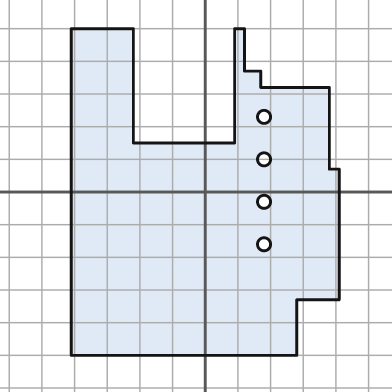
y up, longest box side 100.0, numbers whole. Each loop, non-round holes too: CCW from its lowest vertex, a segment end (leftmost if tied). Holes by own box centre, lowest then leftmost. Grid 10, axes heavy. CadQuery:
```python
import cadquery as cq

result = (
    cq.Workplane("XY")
    .moveTo(-41.0, -50.0)
    .lineTo(28.0, -50.0)
    .lineTo(28.0, -33.0)
    .lineTo(41.0, -33.0)
    .lineTo(41.0, 7.0)
    .lineTo(38.0, 7.0)
    .lineTo(38.0, 32.0)
    .lineTo(17.0, 32.0)
    .lineTo(17.0, 37.0)
    .lineTo(12.0, 37.0)
    .lineTo(12.0, 50.0)
    .lineTo(9.0, 50.0)
    .lineTo(9.0, 15.0)
    .lineTo(-22.0, 15.0)
    .lineTo(-22.0, 50.0)
    .lineTo(-41.0, 50.0)
    .close()
    .moveTo(18.0, -16.0)
    .circle(2.0)
    .moveTo(18.0, -3.0)
    .circle(2.0)
    .moveTo(18.0, 10.0)
    .circle(2.0)
    .moveTo(18.0, 23.0)
    .circle(2.0)
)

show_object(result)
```